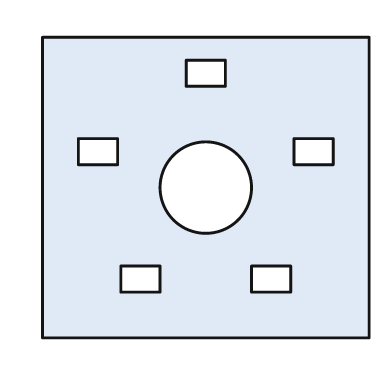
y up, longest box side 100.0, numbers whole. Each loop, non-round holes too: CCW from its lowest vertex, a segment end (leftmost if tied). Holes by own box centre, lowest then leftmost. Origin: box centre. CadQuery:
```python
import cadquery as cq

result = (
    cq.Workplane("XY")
    .moveTo(-50.0, -46.0)
    .lineTo(50.0, -46.0)
    .lineTo(50.0, 46.0)
    .lineTo(-50.0, 46.0)
    .close()
    .moveTo(-26.0, -32.0)
    .lineTo(-14.0, -32.0)
    .lineTo(-14.0, -24.0)
    .lineTo(-26.0, -24.0)
    .close()
    .moveTo(14.0, -32.0)
    .lineTo(26.0, -32.0)
    .lineTo(26.0, -24.0)
    .lineTo(14.0, -24.0)
    .close()
    .moveTo(0.0, 0.0)
    .circle(14.0)
    .moveTo(-39.0, 7.0)
    .lineTo(-27.0, 7.0)
    .lineTo(-27.0, 15.0)
    .lineTo(-39.0, 15.0)
    .close()
    .moveTo(27.0, 7.0)
    .lineTo(39.0, 7.0)
    .lineTo(39.0, 15.0)
    .lineTo(27.0, 15.0)
    .close()
    .moveTo(-6.0, 31.0)
    .lineTo(6.0, 31.0)
    .lineTo(6.0, 39.0)
    .lineTo(-6.0, 39.0)
    .close()
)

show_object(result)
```